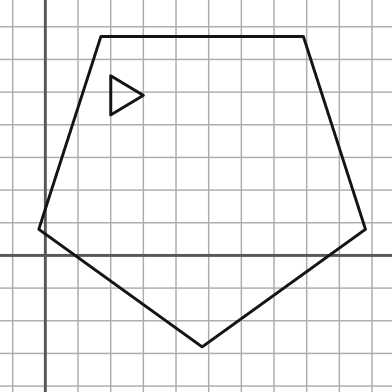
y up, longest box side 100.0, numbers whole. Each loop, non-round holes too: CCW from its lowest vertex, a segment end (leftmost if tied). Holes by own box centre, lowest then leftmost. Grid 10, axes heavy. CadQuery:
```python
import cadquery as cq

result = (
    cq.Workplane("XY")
    .moveTo(48.0, -28.0)
    .lineTo(98.0, 8.0)
    .lineTo(79.0, 67.0)
    .lineTo(17.0, 67.0)
    .lineTo(-2.0, 8.0)
    .close()
    .moveTo(20.0, 43.0)
    .lineTo(30.0, 49.0)
    .lineTo(20.0, 55.0)
    .close()
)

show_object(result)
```